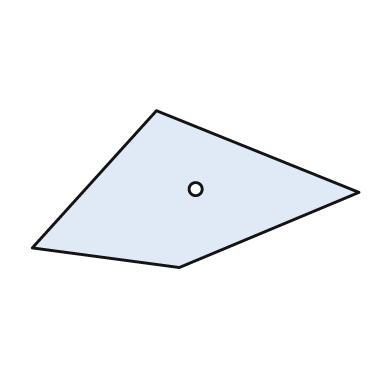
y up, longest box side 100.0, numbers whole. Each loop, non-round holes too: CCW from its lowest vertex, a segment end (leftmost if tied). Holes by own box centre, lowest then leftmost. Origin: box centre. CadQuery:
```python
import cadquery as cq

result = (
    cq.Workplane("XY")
    .moveTo(-5.0, -24.0)
    .lineTo(50.0, -1.0)
    .lineTo(-12.0, 24.0)
    .lineTo(-50.0, -18.0)
    .close()
    .moveTo(0.0, 0.0)
    .circle(2.0)
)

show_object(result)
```